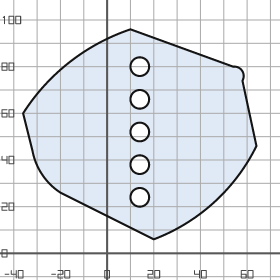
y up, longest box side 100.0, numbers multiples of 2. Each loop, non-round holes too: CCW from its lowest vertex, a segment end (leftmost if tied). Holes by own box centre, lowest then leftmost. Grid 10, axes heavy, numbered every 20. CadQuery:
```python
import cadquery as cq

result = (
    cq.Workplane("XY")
    .moveTo(20.0, 6.0)
    .threePointArc((46.0, 22.0), (64.0, 46.0))
    .lineTo(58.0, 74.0)
    .threePointArc((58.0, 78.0), (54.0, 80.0))
    .lineTo(10.0, 96.0)
    .threePointArc((-16.0, 82.0), (-36.0, 60.0))
    .lineTo(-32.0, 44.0)
    .threePointArc((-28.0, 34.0), (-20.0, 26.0))
    .close()
    .moveTo(14.0, 24.0)
    .circle(4.0)
    .moveTo(14.0, 38.0)
    .circle(4.0)
    .moveTo(14.0, 52.0)
    .circle(4.0)
    .moveTo(14.0, 66.0)
    .circle(4.0)
    .moveTo(14.0, 80.0)
    .circle(4.0)
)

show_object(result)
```